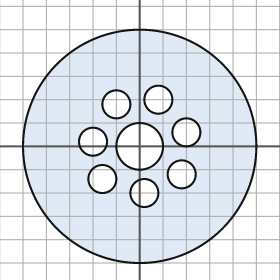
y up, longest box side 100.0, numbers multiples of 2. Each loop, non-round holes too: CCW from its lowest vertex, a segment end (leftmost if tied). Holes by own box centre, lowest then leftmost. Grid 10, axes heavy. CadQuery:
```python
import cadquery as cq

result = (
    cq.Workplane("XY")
    .moveTo(0.0, 0.0)
    .circle(50.0)
    .moveTo(2.0, -20.0)
    .circle(6.0)
    .moveTo(-16.0, -14.0)
    .circle(6.0)
    .moveTo(18.0, -12.0)
    .circle(6.0)
    .moveTo(0.0, 0.0)
    .circle(10.0)
    .moveTo(-20.0, 2.0)
    .circle(6.0)
    .moveTo(20.0, 6.0)
    .circle(6.0)
    .moveTo(-10.0, 18.0)
    .circle(6.0)
    .moveTo(8.0, 20.0)
    .circle(6.0)
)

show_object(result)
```